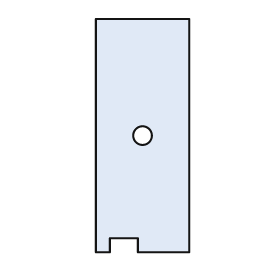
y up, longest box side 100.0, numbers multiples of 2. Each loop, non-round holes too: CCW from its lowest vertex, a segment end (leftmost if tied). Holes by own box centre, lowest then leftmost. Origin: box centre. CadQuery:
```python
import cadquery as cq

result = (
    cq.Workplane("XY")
    .moveTo(-20.0, -50.0)
    .lineTo(-14.0, -50.0)
    .lineTo(-14.0, -44.0)
    .lineTo(-2.0, -44.0)
    .lineTo(-2.0, -50.0)
    .lineTo(20.0, -50.0)
    .lineTo(20.0, 50.0)
    .lineTo(-20.0, 50.0)
    .close()
    .moveTo(0.0, 0.0)
    .circle(4.0)
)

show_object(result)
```